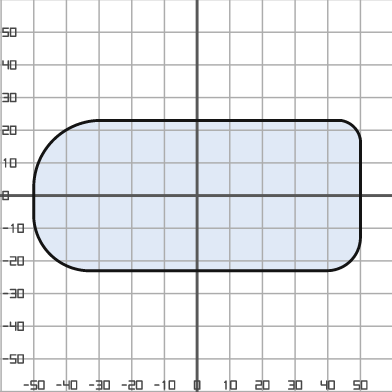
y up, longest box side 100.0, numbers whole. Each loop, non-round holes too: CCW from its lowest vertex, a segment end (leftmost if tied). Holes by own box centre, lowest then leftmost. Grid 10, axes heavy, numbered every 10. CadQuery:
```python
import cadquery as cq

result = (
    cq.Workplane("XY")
    .moveTo(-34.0, -23.0)
    .lineTo(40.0, -23.0)
    .threePointArc((47.0, -20.0), (50.0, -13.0))
    .lineTo(50.0, 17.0)
    .threePointArc((48.0, 21.0), (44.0, 23.0))
    .lineTo(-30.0, 23.0)
    .threePointArc((-44.0, 17.0), (-50.0, 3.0))
    .lineTo(-50.0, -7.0)
    .threePointArc((-45.0, -18.0), (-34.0, -23.0))
    .close()
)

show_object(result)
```